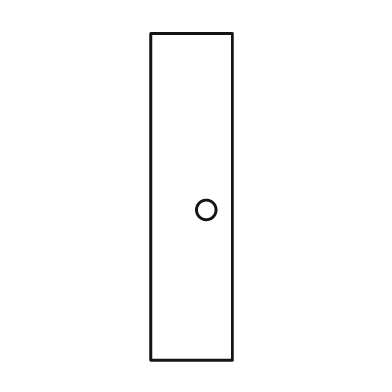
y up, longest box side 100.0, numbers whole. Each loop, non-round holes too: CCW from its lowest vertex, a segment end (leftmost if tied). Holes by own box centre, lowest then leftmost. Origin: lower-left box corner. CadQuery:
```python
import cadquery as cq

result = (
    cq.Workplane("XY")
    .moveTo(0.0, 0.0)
    .lineTo(25.0, 0.0)
    .lineTo(25.0, 100.0)
    .lineTo(0.0, 100.0)
    .close()
    .moveTo(17.0, 46.0)
    .circle(3.0)
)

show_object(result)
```